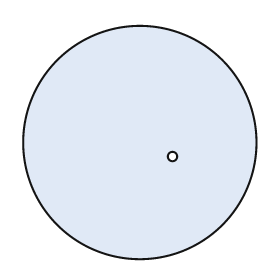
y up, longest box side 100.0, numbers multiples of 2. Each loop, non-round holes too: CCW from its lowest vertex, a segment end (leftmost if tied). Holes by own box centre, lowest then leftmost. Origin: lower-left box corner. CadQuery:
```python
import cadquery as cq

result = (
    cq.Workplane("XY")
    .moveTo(50.0, 50.0)
    .circle(50.0)
    .moveTo(64.0, 44.0)
    .circle(2.0)
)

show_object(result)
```